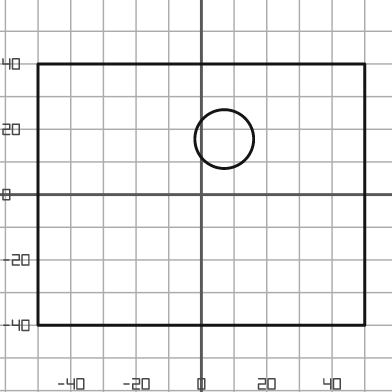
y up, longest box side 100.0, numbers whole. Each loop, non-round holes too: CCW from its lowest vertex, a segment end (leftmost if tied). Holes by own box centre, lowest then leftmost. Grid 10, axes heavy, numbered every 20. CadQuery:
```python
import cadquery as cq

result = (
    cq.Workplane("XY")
    .moveTo(-50.0, -40.0)
    .lineTo(50.0, -40.0)
    .lineTo(50.0, 40.0)
    .lineTo(-50.0, 40.0)
    .close()
    .moveTo(7.0, 17.0)
    .circle(9.0)
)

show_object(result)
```